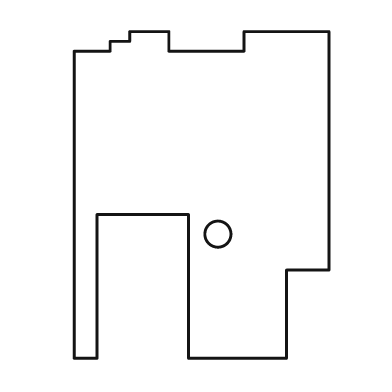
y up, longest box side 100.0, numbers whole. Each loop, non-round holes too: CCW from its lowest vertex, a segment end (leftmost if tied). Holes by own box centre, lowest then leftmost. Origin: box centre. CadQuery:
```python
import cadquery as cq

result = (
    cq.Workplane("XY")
    .moveTo(-39.0, -50.0)
    .lineTo(-32.0, -50.0)
    .lineTo(-32.0, -6.0)
    .lineTo(-4.0, -6.0)
    .lineTo(-4.0, -50.0)
    .lineTo(26.0, -50.0)
    .lineTo(26.0, -23.0)
    .lineTo(39.0, -23.0)
    .lineTo(39.0, 50.0)
    .lineTo(13.0, 50.0)
    .lineTo(13.0, 44.0)
    .lineTo(-10.0, 44.0)
    .lineTo(-10.0, 50.0)
    .lineTo(-22.0, 50.0)
    .lineTo(-22.0, 47.0)
    .lineTo(-28.0, 47.0)
    .lineTo(-28.0, 44.0)
    .lineTo(-39.0, 44.0)
    .close()
    .moveTo(5.0, -12.0)
    .circle(4.0)
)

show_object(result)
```